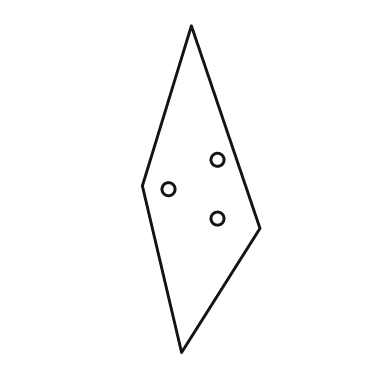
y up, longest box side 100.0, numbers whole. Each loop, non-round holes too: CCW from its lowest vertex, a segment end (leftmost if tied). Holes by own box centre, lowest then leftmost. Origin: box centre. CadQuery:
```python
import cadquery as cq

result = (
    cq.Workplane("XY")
    .moveTo(-6.0, -50.0)
    .lineTo(18.0, -12.0)
    .lineTo(-3.0, 50.0)
    .lineTo(-18.0, 1.0)
    .close()
    .moveTo(5.0, -9.0)
    .circle(2.0)
    .moveTo(-10.0, 0.0)
    .circle(2.0)
    .moveTo(5.0, 9.0)
    .circle(2.0)
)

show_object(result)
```